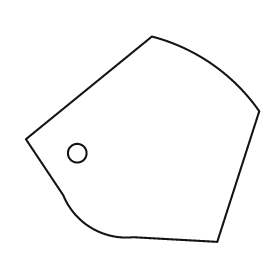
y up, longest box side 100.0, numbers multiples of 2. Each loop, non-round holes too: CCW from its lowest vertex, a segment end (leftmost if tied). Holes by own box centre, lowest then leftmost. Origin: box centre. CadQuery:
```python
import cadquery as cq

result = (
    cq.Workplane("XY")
    .moveTo(32.0, -44.0)
    .lineTo(50.0, 12.0)
    .threePointArc((30.0, 32.0), (4.0, 44.0))
    .lineTo(-50.0, 0.0)
    .lineTo(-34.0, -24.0)
    .threePointArc((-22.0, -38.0), (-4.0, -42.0))
    .close()
    .moveTo(-28.0, -6.0)
    .circle(4.0)
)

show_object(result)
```